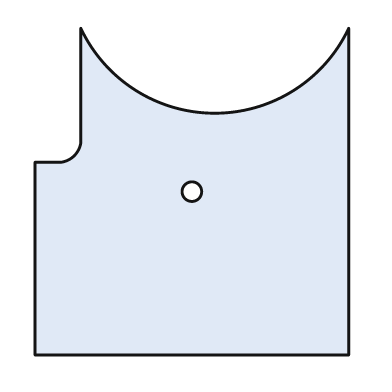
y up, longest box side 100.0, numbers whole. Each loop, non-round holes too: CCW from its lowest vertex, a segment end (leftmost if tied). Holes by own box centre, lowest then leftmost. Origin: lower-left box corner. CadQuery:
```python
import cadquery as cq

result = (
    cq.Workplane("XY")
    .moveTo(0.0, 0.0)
    .lineTo(96.0, 0.0)
    .lineTo(96.0, 100.0)
    .threePointArc((55.0, 74.0), (14.0, 100.0))
    .lineTo(14.0, 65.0)
    .threePointArc((12.0, 61.0), (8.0, 59.0))
    .lineTo(0.0, 59.0)
    .close()
    .moveTo(48.0, 50.0)
    .circle(3.0)
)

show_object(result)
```